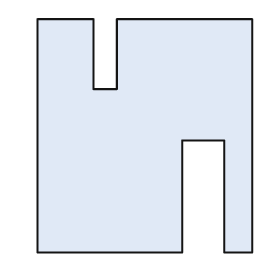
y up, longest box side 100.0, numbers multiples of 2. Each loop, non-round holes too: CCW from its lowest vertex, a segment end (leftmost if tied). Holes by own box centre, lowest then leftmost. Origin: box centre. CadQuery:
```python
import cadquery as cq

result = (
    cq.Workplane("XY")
    .moveTo(-46.0, -50.0)
    .lineTo(16.0, -50.0)
    .lineTo(16.0, -2.0)
    .lineTo(34.0, -2.0)
    .lineTo(34.0, -50.0)
    .lineTo(46.0, -50.0)
    .lineTo(46.0, 50.0)
    .lineTo(-12.0, 50.0)
    .lineTo(-12.0, 20.0)
    .lineTo(-22.0, 20.0)
    .lineTo(-22.0, 50.0)
    .lineTo(-46.0, 50.0)
    .close()
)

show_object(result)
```